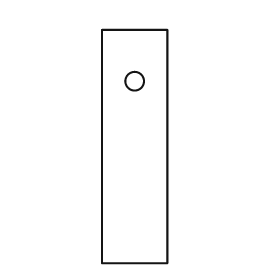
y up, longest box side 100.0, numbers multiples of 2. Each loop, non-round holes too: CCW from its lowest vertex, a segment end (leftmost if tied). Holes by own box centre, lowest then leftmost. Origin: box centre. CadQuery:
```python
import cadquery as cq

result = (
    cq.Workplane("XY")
    .moveTo(-14.0, -50.0)
    .lineTo(14.0, -50.0)
    .lineTo(14.0, 50.0)
    .lineTo(-14.0, 50.0)
    .close()
    .moveTo(0.0, 28.0)
    .circle(4.0)
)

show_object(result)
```